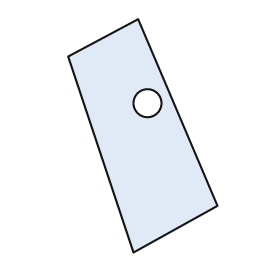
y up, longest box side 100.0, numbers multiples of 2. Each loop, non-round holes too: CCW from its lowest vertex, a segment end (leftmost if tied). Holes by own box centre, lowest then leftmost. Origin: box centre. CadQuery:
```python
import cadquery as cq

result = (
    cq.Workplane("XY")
    .moveTo(-4.0, -50.0)
    .lineTo(32.0, -30.0)
    .lineTo(-2.0, 50.0)
    .lineTo(-32.0, 34.0)
    .close()
    .moveTo(2.0, 14.0)
    .circle(6.0)
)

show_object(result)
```